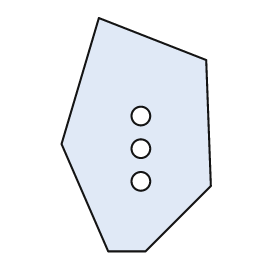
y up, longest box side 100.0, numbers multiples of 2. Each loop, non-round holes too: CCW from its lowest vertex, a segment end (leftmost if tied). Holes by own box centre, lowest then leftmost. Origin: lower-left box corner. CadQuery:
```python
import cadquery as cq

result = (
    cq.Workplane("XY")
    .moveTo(20.0, 0.0)
    .lineTo(36.0, 0.0)
    .lineTo(64.0, 28.0)
    .lineTo(62.0, 82.0)
    .lineTo(16.0, 100.0)
    .lineTo(0.0, 46.0)
    .close()
    .moveTo(34.0, 30.0)
    .circle(4.0)
    .moveTo(34.0, 44.0)
    .circle(4.0)
    .moveTo(34.0, 58.0)
    .circle(4.0)
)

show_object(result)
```